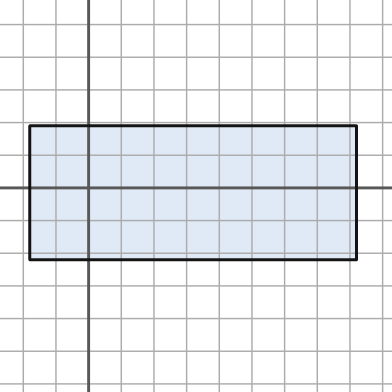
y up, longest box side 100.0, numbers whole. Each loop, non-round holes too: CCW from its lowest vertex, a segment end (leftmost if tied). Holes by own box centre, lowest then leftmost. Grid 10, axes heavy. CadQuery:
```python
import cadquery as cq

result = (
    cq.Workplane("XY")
    .moveTo(-18.0, -22.0)
    .lineTo(82.0, -22.0)
    .lineTo(82.0, 19.0)
    .lineTo(-18.0, 19.0)
    .close()
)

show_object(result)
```